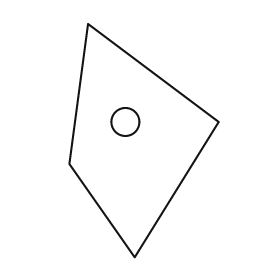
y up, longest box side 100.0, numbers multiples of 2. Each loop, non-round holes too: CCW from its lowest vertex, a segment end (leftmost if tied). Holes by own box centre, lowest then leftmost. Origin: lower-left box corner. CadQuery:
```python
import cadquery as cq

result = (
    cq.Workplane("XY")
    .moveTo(28.0, 0.0)
    .lineTo(64.0, 58.0)
    .lineTo(8.0, 100.0)
    .lineTo(0.0, 40.0)
    .close()
    .moveTo(24.0, 58.0)
    .circle(6.0)
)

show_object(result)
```